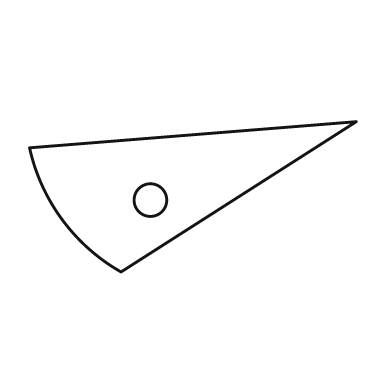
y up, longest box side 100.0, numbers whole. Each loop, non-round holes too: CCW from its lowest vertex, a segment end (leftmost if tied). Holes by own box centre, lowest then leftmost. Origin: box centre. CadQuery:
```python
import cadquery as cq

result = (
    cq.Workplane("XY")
    .moveTo(-22.0, -23.0)
    .lineTo(50.0, 23.0)
    .lineTo(-50.0, 15.0)
    .threePointArc((-40.0, -7.0), (-22.0, -23.0))
    .close()
    .moveTo(-13.0, -1.0)
    .circle(5.0)
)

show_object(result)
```